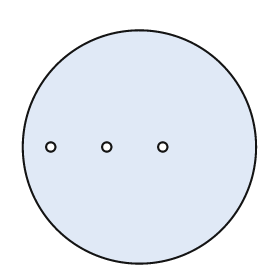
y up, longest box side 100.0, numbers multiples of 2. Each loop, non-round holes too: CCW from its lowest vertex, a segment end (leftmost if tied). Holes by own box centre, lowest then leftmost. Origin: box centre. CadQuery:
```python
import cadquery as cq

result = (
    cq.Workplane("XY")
    .moveTo(0.0, 0.0)
    .circle(50.0)
    .moveTo(-38.0, 0.0)
    .circle(2.0)
    .moveTo(-14.0, 0.0)
    .circle(2.0)
    .moveTo(10.0, 0.0)
    .circle(2.0)
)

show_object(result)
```